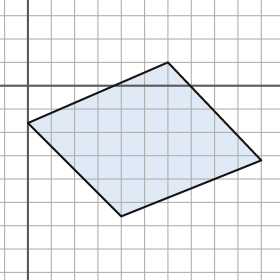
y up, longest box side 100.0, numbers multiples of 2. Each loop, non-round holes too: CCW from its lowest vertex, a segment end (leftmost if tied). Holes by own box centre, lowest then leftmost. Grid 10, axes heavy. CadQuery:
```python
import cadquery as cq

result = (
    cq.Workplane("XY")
    .moveTo(40.0, -56.0)
    .lineTo(100.0, -32.0)
    .lineTo(60.0, 10.0)
    .lineTo(0.0, -16.0)
    .close()
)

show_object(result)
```